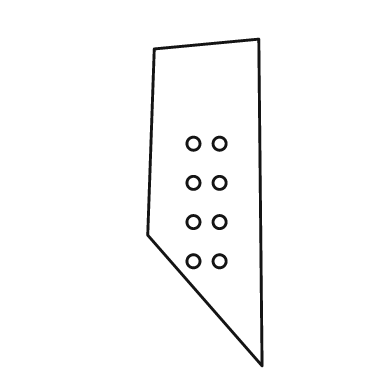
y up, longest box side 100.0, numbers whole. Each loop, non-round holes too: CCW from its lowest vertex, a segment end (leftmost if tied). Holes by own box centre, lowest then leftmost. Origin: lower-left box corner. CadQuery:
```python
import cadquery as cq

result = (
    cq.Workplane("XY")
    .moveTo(35.0, 0.0)
    .lineTo(34.0, 100.0)
    .lineTo(2.0, 97.0)
    .lineTo(0.0, 40.0)
    .close()
    .moveTo(14.0, 32.0)
    .circle(2.0)
    .moveTo(22.0, 32.0)
    .circle(2.0)
    .moveTo(14.0, 44.0)
    .circle(2.0)
    .moveTo(22.0, 44.0)
    .circle(2.0)
    .moveTo(14.0, 56.0)
    .circle(2.0)
    .moveTo(22.0, 56.0)
    .circle(2.0)
    .moveTo(14.0, 68.0)
    .circle(2.0)
    .moveTo(22.0, 68.0)
    .circle(2.0)
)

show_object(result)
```